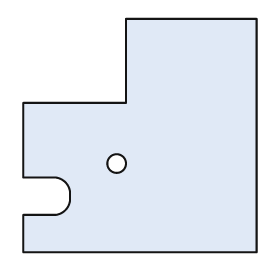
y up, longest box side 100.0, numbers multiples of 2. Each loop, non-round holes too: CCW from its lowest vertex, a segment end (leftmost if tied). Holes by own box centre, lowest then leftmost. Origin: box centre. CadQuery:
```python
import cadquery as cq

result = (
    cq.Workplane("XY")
    .moveTo(-50.0, -50.0)
    .lineTo(50.0, -50.0)
    .lineTo(50.0, 50.0)
    .lineTo(-6.0, 50.0)
    .lineTo(-6.0, 14.0)
    .lineTo(-50.0, 14.0)
    .lineTo(-50.0, -18.0)
    .lineTo(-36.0, -18.0)
    .threePointArc((-32.0, -20.0), (-30.0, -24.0))
    .lineTo(-30.0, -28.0)
    .threePointArc((-32.0, -32.0), (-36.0, -34.0))
    .lineTo(-50.0, -34.0)
    .close()
    .moveTo(-10.0, -12.0)
    .circle(4.0)
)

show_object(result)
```